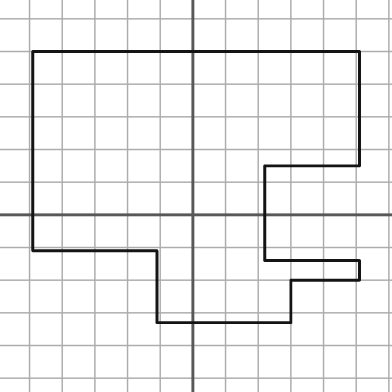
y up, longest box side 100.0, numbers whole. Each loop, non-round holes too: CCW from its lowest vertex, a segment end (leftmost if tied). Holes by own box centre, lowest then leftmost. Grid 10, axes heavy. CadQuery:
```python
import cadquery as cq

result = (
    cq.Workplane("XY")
    .moveTo(-11.0, -33.0)
    .lineTo(30.0, -33.0)
    .lineTo(30.0, -20.0)
    .lineTo(51.0, -20.0)
    .lineTo(51.0, -14.0)
    .lineTo(22.0, -14.0)
    .lineTo(22.0, 15.0)
    .lineTo(51.0, 15.0)
    .lineTo(51.0, 50.0)
    .lineTo(-49.0, 50.0)
    .lineTo(-49.0, -11.0)
    .lineTo(-11.0, -11.0)
    .close()
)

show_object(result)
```